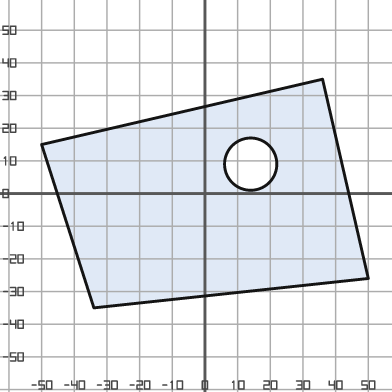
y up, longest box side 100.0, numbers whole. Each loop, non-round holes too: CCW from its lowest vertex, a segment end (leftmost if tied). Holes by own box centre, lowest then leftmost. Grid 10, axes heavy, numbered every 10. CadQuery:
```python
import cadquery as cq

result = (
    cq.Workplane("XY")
    .moveTo(-34.0, -35.0)
    .lineTo(50.0, -26.0)
    .lineTo(36.0, 35.0)
    .lineTo(-50.0, 15.0)
    .close()
    .moveTo(14.0, 9.0)
    .circle(8.0)
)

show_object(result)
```